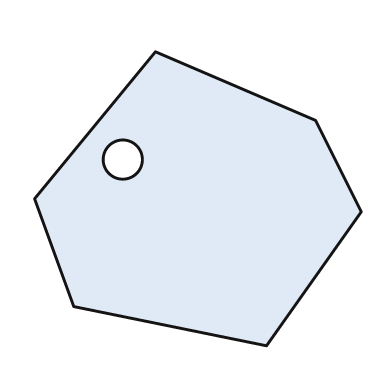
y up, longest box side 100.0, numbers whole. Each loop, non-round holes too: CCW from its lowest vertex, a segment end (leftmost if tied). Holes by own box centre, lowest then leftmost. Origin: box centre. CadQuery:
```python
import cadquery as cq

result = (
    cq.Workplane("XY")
    .moveTo(21.0, -45.0)
    .lineTo(50.0, -4.0)
    .lineTo(36.0, 24.0)
    .lineTo(-13.0, 45.0)
    .lineTo(-50.0, 0.0)
    .lineTo(-38.0, -33.0)
    .close()
    .moveTo(-23.0, 12.0)
    .circle(6.0)
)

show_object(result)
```